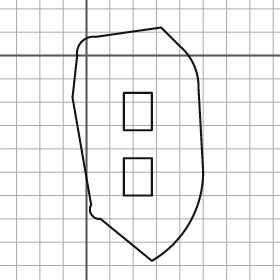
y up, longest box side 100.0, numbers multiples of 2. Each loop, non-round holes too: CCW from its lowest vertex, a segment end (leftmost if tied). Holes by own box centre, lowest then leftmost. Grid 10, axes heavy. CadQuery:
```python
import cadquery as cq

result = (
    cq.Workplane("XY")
    .moveTo(28.0, -88.0)
    .threePointArc((44.0, -72.0), (50.0, -50.0))
    .lineTo(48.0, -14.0)
    .threePointArc((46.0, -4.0), (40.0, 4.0))
    .lineTo(32.0, 12.0)
    .lineTo(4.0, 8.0)
    .threePointArc((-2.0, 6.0), (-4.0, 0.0))
    .lineTo(-6.0, -18.0)
    .lineTo(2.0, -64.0)
    .threePointArc((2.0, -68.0), (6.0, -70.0))
    .close()
    .moveTo(16.0, -60.0)
    .lineTo(28.0, -60.0)
    .lineTo(28.0, -44.0)
    .lineTo(16.0, -44.0)
    .close()
    .moveTo(16.0, -32.0)
    .lineTo(28.0, -32.0)
    .lineTo(28.0, -16.0)
    .lineTo(16.0, -16.0)
    .close()
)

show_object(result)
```